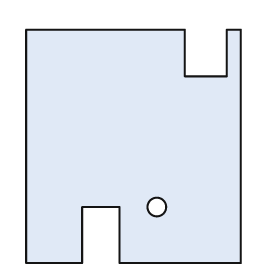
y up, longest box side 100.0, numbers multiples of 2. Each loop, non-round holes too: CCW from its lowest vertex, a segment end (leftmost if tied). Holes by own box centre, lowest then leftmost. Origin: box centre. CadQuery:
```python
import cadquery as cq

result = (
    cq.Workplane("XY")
    .moveTo(-46.0, -50.0)
    .lineTo(-22.0, -50.0)
    .lineTo(-22.0, -26.0)
    .lineTo(-6.0, -26.0)
    .lineTo(-6.0, -50.0)
    .lineTo(46.0, -50.0)
    .lineTo(46.0, 50.0)
    .lineTo(40.0, 50.0)
    .lineTo(40.0, 30.0)
    .lineTo(22.0, 30.0)
    .lineTo(22.0, 50.0)
    .lineTo(-46.0, 50.0)
    .close()
    .moveTo(10.0, -26.0)
    .circle(4.0)
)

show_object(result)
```